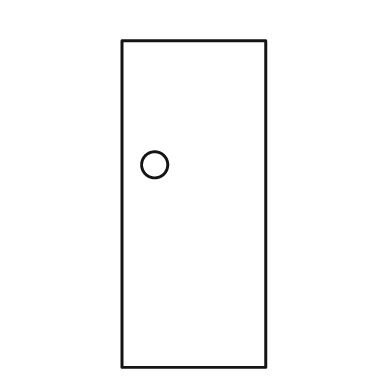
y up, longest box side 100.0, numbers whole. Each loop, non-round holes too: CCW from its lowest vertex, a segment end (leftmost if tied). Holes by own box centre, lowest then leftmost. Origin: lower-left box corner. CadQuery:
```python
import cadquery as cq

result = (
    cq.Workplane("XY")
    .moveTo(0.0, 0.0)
    .lineTo(44.0, 0.0)
    .lineTo(44.0, 100.0)
    .lineTo(0.0, 100.0)
    .close()
    .moveTo(10.0, 62.0)
    .circle(4.0)
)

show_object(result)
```